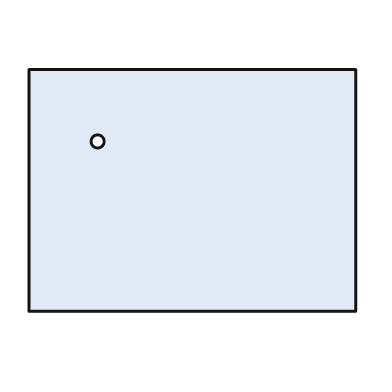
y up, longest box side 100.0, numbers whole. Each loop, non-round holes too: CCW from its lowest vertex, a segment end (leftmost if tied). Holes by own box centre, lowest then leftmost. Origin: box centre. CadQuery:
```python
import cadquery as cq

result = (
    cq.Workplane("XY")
    .moveTo(-50.0, -37.0)
    .lineTo(50.0, -37.0)
    .lineTo(50.0, 37.0)
    .lineTo(-50.0, 37.0)
    .close()
    .moveTo(-29.0, 15.0)
    .circle(2.0)
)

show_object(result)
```